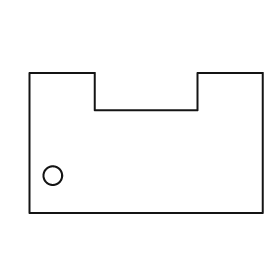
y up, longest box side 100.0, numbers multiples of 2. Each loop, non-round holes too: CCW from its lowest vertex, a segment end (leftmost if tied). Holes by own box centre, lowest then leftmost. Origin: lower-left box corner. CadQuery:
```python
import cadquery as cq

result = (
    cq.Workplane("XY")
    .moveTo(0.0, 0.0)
    .lineTo(100.0, 0.0)
    .lineTo(100.0, 60.0)
    .lineTo(72.0, 60.0)
    .lineTo(72.0, 44.0)
    .lineTo(28.0, 44.0)
    .lineTo(28.0, 60.0)
    .lineTo(0.0, 60.0)
    .close()
    .moveTo(10.0, 16.0)
    .circle(4.0)
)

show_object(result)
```